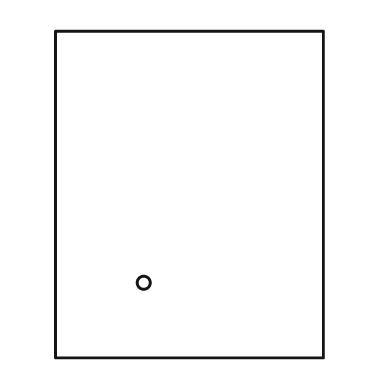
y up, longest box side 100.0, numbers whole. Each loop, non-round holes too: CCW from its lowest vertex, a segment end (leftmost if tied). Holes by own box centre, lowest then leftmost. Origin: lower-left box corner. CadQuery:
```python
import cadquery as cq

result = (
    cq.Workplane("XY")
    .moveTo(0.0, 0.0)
    .lineTo(82.0, 0.0)
    .lineTo(82.0, 100.0)
    .lineTo(0.0, 100.0)
    .close()
    .moveTo(27.0, 23.0)
    .circle(2.0)
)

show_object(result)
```